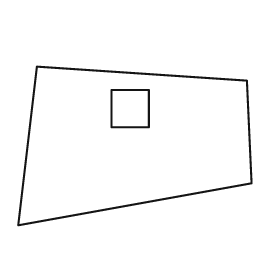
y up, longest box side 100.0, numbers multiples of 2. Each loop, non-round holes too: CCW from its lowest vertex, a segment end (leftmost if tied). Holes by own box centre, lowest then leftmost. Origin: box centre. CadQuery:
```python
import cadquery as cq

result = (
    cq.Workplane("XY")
    .moveTo(-50.0, -34.0)
    .lineTo(50.0, -16.0)
    .lineTo(48.0, 28.0)
    .lineTo(-42.0, 34.0)
    .close()
    .moveTo(-10.0, 8.0)
    .lineTo(6.0, 8.0)
    .lineTo(6.0, 24.0)
    .lineTo(-10.0, 24.0)
    .close()
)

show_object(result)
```